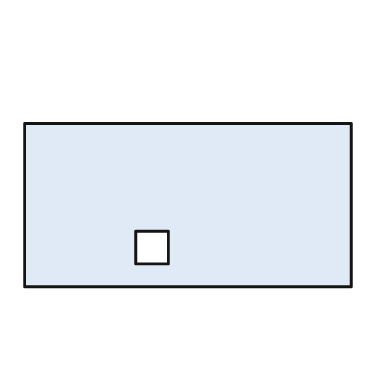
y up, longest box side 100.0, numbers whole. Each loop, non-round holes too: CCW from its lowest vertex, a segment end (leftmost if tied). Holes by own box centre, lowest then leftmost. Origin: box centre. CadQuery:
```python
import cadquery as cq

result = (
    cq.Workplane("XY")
    .moveTo(-50.0, -25.0)
    .lineTo(50.0, -25.0)
    .lineTo(50.0, 25.0)
    .lineTo(-50.0, 25.0)
    .close()
    .moveTo(-16.0, -18.0)
    .lineTo(-6.0, -18.0)
    .lineTo(-6.0, -8.0)
    .lineTo(-16.0, -8.0)
    .close()
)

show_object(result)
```